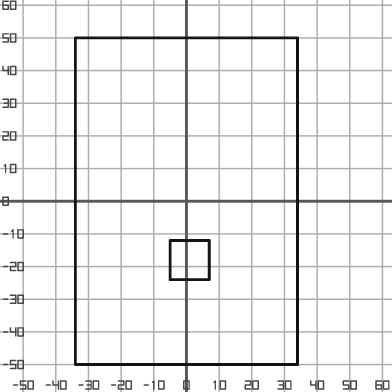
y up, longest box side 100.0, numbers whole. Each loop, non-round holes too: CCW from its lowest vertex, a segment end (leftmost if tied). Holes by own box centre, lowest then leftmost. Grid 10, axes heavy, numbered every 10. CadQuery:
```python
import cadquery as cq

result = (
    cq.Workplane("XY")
    .moveTo(-34.0, -50.0)
    .lineTo(34.0, -50.0)
    .lineTo(34.0, 50.0)
    .lineTo(-34.0, 50.0)
    .close()
    .moveTo(-5.0, -24.0)
    .lineTo(7.0, -24.0)
    .lineTo(7.0, -12.0)
    .lineTo(-5.0, -12.0)
    .close()
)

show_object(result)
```